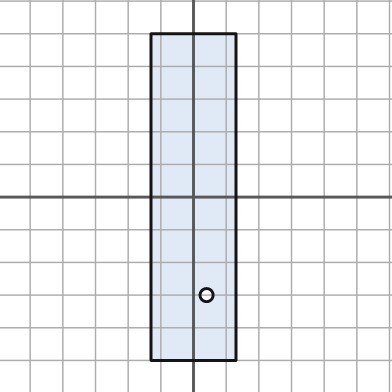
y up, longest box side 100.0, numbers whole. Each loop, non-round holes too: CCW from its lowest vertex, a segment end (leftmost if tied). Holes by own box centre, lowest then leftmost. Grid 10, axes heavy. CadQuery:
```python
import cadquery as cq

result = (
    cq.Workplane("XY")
    .moveTo(-13.0, -50.0)
    .lineTo(13.0, -50.0)
    .lineTo(13.0, 50.0)
    .lineTo(-13.0, 50.0)
    .close()
    .moveTo(4.0, -30.0)
    .circle(2.0)
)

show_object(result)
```